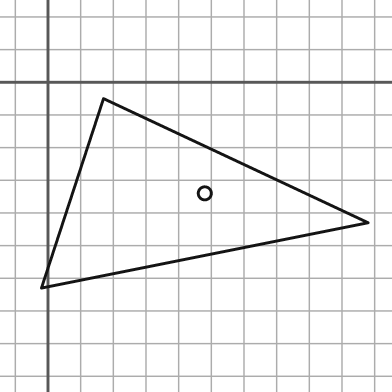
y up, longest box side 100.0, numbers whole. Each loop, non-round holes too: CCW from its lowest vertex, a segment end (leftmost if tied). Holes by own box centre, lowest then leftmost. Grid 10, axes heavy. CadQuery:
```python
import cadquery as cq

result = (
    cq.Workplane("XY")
    .moveTo(-2.0, -63.0)
    .lineTo(98.0, -43.0)
    .lineTo(17.0, -5.0)
    .close()
    .moveTo(48.0, -34.0)
    .circle(2.0)
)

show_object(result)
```